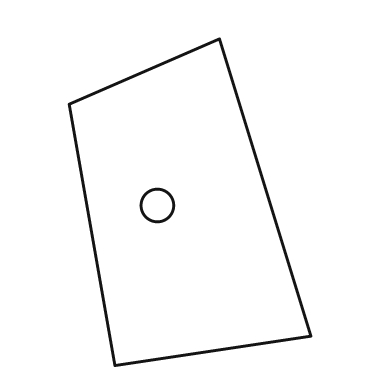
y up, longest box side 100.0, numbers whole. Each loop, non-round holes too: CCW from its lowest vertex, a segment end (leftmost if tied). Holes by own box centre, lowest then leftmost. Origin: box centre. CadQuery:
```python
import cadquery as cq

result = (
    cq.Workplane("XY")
    .moveTo(-23.0, -50.0)
    .lineTo(37.0, -41.0)
    .lineTo(9.0, 50.0)
    .lineTo(-37.0, 30.0)
    .close()
    .moveTo(-10.0, -1.0)
    .circle(5.0)
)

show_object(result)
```